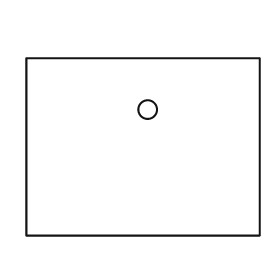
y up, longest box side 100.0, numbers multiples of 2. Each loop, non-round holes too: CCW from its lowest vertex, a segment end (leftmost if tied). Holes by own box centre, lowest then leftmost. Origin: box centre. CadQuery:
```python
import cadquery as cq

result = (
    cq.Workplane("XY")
    .moveTo(-50.0, -38.0)
    .lineTo(50.0, -38.0)
    .lineTo(50.0, 38.0)
    .lineTo(-50.0, 38.0)
    .close()
    .moveTo(2.0, 16.0)
    .circle(4.0)
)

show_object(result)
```